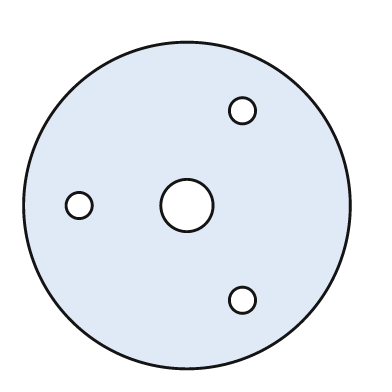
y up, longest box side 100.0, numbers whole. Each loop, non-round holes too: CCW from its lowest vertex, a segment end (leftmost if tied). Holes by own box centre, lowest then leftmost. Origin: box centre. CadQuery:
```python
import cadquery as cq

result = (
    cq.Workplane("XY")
    .moveTo(0.0, 0.0)
    .circle(50.0)
    .moveTo(17.0, -29.0)
    .circle(4.0)
    .moveTo(-33.0, 0.0)
    .circle(4.0)
    .moveTo(0.0, 0.0)
    .circle(8.0)
    .moveTo(17.0, 29.0)
    .circle(4.0)
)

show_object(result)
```